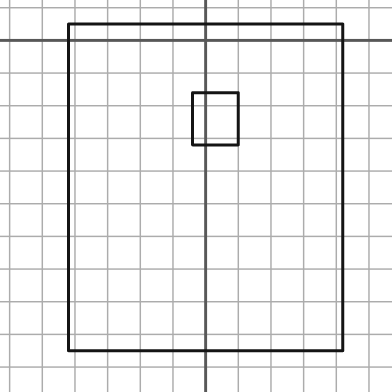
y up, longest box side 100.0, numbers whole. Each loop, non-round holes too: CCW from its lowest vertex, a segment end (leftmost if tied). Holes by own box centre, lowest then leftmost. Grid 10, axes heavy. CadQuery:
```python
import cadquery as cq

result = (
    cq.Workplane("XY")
    .moveTo(-42.0, -95.0)
    .lineTo(42.0, -95.0)
    .lineTo(42.0, 5.0)
    .lineTo(-42.0, 5.0)
    .close()
    .moveTo(-4.0, -32.0)
    .lineTo(10.0, -32.0)
    .lineTo(10.0, -16.0)
    .lineTo(-4.0, -16.0)
    .close()
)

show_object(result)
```